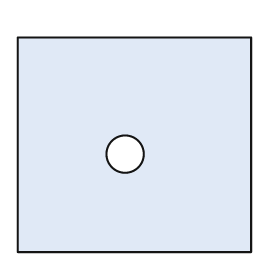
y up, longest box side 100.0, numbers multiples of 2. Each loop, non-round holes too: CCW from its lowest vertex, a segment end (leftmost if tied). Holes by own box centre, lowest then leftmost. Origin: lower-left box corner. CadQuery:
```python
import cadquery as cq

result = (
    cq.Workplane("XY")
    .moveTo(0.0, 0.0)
    .lineTo(100.0, 0.0)
    .lineTo(100.0, 92.0)
    .lineTo(0.0, 92.0)
    .close()
    .moveTo(46.0, 42.0)
    .circle(8.0)
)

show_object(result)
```